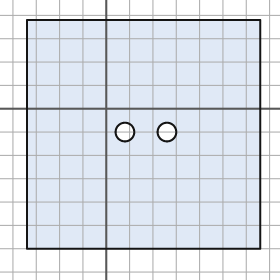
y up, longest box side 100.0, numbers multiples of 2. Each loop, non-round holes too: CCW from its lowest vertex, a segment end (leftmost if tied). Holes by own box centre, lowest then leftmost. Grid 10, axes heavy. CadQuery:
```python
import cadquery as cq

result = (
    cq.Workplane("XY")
    .moveTo(-34.0, -60.0)
    .lineTo(66.0, -60.0)
    .lineTo(66.0, 38.0)
    .lineTo(-34.0, 38.0)
    .close()
    .moveTo(8.0, -10.0)
    .circle(4.0)
    .moveTo(26.0, -10.0)
    .circle(4.0)
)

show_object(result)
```